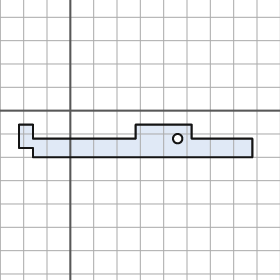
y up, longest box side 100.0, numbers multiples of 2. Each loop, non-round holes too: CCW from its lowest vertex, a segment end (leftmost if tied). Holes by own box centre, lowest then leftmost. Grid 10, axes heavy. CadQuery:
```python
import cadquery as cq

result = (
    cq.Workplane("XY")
    .moveTo(-16.0, -20.0)
    .lineTo(78.0, -20.0)
    .lineTo(78.0, -12.0)
    .lineTo(52.0, -12.0)
    .lineTo(52.0, -6.0)
    .lineTo(28.0, -6.0)
    .lineTo(28.0, -12.0)
    .lineTo(-16.0, -12.0)
    .lineTo(-16.0, -6.0)
    .lineTo(-22.0, -6.0)
    .lineTo(-22.0, -16.0)
    .lineTo(-16.0, -16.0)
    .close()
    .moveTo(46.0, -12.0)
    .circle(2.0)
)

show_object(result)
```